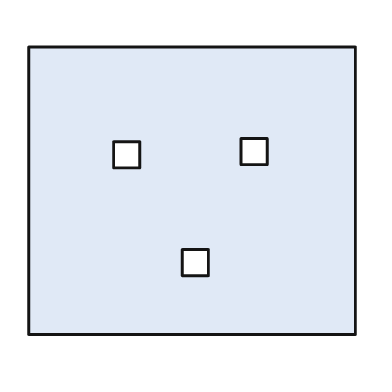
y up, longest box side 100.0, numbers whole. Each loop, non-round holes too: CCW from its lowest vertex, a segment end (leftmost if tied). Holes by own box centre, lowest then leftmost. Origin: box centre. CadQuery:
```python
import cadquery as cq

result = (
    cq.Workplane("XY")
    .moveTo(-50.0, -44.0)
    .lineTo(50.0, -44.0)
    .lineTo(50.0, 44.0)
    .lineTo(-50.0, 44.0)
    .close()
    .moveTo(-3.0, -26.0)
    .lineTo(5.0, -26.0)
    .lineTo(5.0, -18.0)
    .lineTo(-3.0, -18.0)
    .close()
    .moveTo(-24.0, 7.0)
    .lineTo(-16.0, 7.0)
    .lineTo(-16.0, 15.0)
    .lineTo(-24.0, 15.0)
    .close()
    .moveTo(15.0, 8.0)
    .lineTo(23.0, 8.0)
    .lineTo(23.0, 16.0)
    .lineTo(15.0, 16.0)
    .close()
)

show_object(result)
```